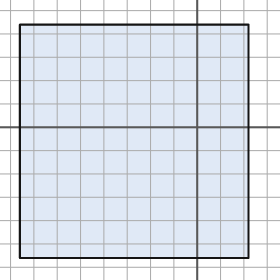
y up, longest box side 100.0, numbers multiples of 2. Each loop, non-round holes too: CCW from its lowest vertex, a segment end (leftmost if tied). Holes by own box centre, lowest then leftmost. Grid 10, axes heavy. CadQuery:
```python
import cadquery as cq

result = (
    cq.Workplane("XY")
    .moveTo(-76.0, -56.0)
    .lineTo(22.0, -56.0)
    .lineTo(22.0, 44.0)
    .lineTo(-76.0, 44.0)
    .close()
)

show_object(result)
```